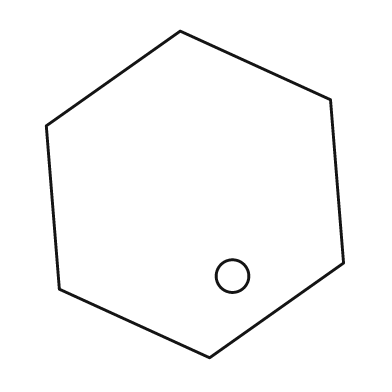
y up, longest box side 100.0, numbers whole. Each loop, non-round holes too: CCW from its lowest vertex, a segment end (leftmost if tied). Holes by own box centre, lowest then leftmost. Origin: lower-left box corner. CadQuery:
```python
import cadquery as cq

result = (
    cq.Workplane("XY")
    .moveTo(50.0, 0.0)
    .lineTo(91.0, 29.0)
    .lineTo(87.0, 79.0)
    .lineTo(41.0, 100.0)
    .lineTo(0.0, 71.0)
    .lineTo(4.0, 21.0)
    .close()
    .moveTo(57.0, 25.0)
    .circle(5.0)
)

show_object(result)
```